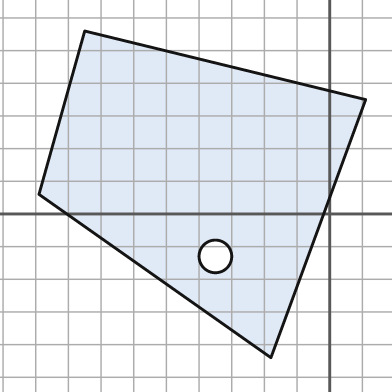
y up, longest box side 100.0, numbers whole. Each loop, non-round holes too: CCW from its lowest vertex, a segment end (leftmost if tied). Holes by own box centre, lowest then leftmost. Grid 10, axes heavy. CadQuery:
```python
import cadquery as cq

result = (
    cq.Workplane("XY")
    .moveTo(-18.0, -44.0)
    .lineTo(11.0, 35.0)
    .lineTo(-75.0, 56.0)
    .lineTo(-89.0, 6.0)
    .close()
    .moveTo(-35.0, -13.0)
    .circle(5.0)
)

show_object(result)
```